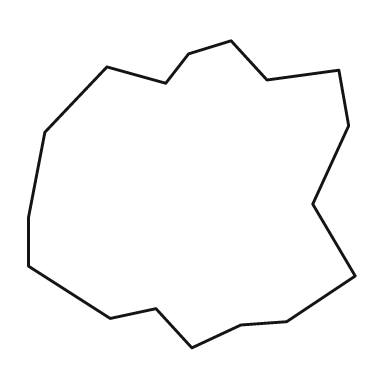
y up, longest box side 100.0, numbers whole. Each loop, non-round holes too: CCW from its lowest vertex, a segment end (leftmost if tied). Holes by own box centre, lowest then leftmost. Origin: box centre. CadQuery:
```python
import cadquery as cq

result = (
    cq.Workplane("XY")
    .moveTo(0.0, -47.0)
    .lineTo(15.0, -40.0)
    .lineTo(29.0, -39.0)
    .lineTo(50.0, -25.0)
    .lineTo(37.0, -3.0)
    .lineTo(48.0, 21.0)
    .lineTo(45.0, 38.0)
    .lineTo(23.0, 35.0)
    .lineTo(12.0, 47.0)
    .lineTo(-1.0, 43.0)
    .lineTo(-8.0, 34.0)
    .lineTo(-26.0, 39.0)
    .lineTo(-45.0, 19.0)
    .lineTo(-50.0, -7.0)
    .lineTo(-50.0, -22.0)
    .lineTo(-25.0, -38.0)
    .lineTo(-11.0, -35.0)
    .close()
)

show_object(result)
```